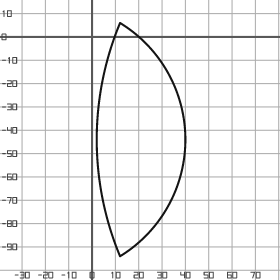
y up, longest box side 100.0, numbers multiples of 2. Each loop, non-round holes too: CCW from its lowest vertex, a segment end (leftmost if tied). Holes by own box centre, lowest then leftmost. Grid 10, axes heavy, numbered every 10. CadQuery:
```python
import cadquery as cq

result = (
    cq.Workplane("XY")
    .moveTo(12.0, -94.0)
    .threePointArc((40.0, -44.0), (12.0, 6.0))
    .threePointArc((2.0, -44.0), (12.0, -94.0))
    .close()
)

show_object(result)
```